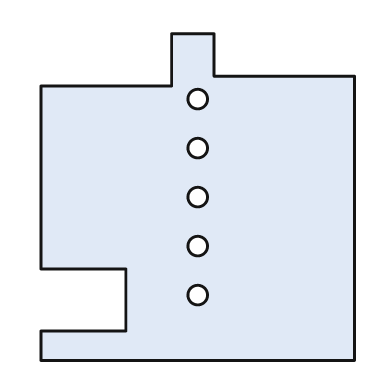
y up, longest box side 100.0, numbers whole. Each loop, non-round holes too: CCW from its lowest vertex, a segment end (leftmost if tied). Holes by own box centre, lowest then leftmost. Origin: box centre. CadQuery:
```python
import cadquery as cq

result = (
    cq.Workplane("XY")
    .moveTo(-48.0, -50.0)
    .lineTo(48.0, -50.0)
    .lineTo(48.0, 37.0)
    .lineTo(5.0, 37.0)
    .lineTo(5.0, 50.0)
    .lineTo(-8.0, 50.0)
    .lineTo(-8.0, 34.0)
    .lineTo(-48.0, 34.0)
    .lineTo(-48.0, -22.0)
    .lineTo(-22.0, -22.0)
    .lineTo(-22.0, -41.0)
    .lineTo(-48.0, -41.0)
    .close()
    .moveTo(0.0, -30.0)
    .circle(3.0)
    .moveTo(0.0, -15.0)
    .circle(3.0)
    .moveTo(0.0, 0.0)
    .circle(3.0)
    .moveTo(0.0, 15.0)
    .circle(3.0)
    .moveTo(0.0, 30.0)
    .circle(3.0)
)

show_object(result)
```